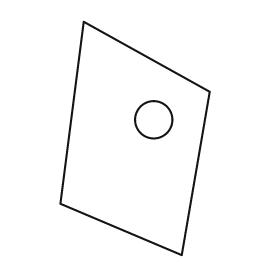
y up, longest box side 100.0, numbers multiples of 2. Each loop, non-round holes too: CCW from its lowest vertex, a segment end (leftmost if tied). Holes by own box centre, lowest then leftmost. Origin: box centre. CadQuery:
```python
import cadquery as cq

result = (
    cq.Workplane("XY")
    .moveTo(20.0, -50.0)
    .lineTo(32.0, 20.0)
    .lineTo(-22.0, 50.0)
    .lineTo(-32.0, -28.0)
    .close()
    .moveTo(8.0, 8.0)
    .circle(8.0)
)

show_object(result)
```